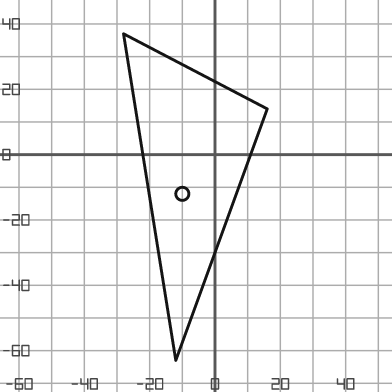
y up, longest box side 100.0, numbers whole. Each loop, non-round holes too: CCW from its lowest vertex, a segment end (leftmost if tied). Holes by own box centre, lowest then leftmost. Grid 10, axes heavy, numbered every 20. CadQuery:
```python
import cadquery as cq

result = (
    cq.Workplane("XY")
    .moveTo(-12.0, -63.0)
    .lineTo(16.0, 14.0)
    .lineTo(-28.0, 37.0)
    .close()
    .moveTo(-10.0, -12.0)
    .circle(2.0)
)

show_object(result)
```